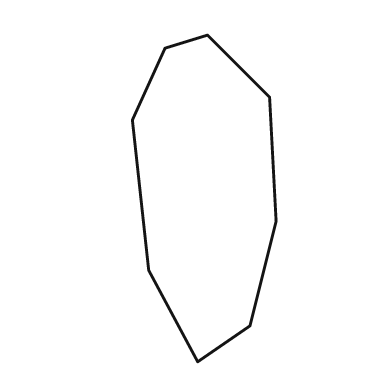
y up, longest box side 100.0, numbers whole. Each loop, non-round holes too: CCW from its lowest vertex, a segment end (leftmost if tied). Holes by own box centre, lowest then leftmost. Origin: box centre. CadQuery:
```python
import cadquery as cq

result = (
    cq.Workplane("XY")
    .moveTo(-2.0, -50.0)
    .lineTo(14.0, -39.0)
    .lineTo(22.0, -7.0)
    .lineTo(20.0, 31.0)
    .lineTo(1.0, 50.0)
    .lineTo(-12.0, 46.0)
    .lineTo(-22.0, 24.0)
    .lineTo(-17.0, -22.0)
    .close()
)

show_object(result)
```